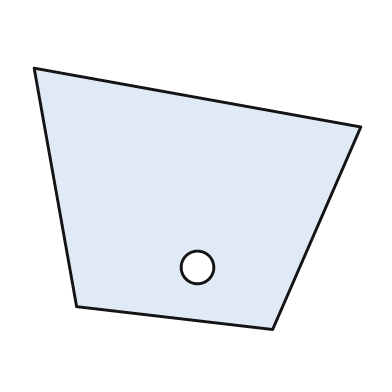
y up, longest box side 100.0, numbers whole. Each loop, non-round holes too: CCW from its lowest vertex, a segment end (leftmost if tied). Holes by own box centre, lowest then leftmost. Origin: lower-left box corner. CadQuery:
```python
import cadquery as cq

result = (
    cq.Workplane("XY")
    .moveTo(73.0, 0.0)
    .lineTo(100.0, 62.0)
    .lineTo(0.0, 80.0)
    .lineTo(13.0, 7.0)
    .close()
    .moveTo(50.0, 19.0)
    .circle(5.0)
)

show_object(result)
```